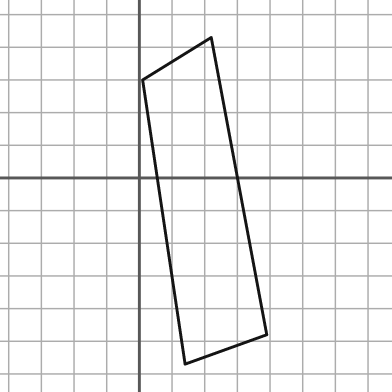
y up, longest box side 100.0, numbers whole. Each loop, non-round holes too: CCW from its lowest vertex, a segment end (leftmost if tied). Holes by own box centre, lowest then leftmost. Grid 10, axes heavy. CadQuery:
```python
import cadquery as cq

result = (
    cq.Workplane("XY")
    .moveTo(14.0, -57.0)
    .lineTo(39.0, -48.0)
    .lineTo(22.0, 43.0)
    .lineTo(1.0, 30.0)
    .close()
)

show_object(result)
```